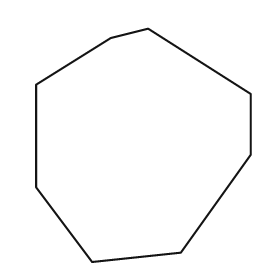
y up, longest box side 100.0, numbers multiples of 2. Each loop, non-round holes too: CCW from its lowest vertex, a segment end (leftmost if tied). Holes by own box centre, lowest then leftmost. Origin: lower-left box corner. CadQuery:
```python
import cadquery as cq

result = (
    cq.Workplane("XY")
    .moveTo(24.0, 0.0)
    .lineTo(62.0, 4.0)
    .lineTo(92.0, 46.0)
    .lineTo(92.0, 72.0)
    .lineTo(48.0, 100.0)
    .lineTo(32.0, 96.0)
    .lineTo(0.0, 76.0)
    .lineTo(0.0, 32.0)
    .close()
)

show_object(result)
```